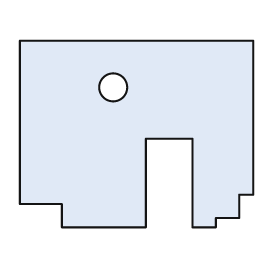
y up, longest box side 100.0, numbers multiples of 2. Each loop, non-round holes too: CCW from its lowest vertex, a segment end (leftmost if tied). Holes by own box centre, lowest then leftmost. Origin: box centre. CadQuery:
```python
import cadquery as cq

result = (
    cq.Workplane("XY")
    .moveTo(-32.0, -40.0)
    .lineTo(4.0, -40.0)
    .lineTo(4.0, -2.0)
    .lineTo(24.0, -2.0)
    .lineTo(24.0, -40.0)
    .lineTo(34.0, -40.0)
    .lineTo(34.0, -36.0)
    .lineTo(44.0, -36.0)
    .lineTo(44.0, -26.0)
    .lineTo(50.0, -26.0)
    .lineTo(50.0, 40.0)
    .lineTo(-50.0, 40.0)
    .lineTo(-50.0, -30.0)
    .lineTo(-32.0, -30.0)
    .close()
    .moveTo(-10.0, 20.0)
    .circle(6.0)
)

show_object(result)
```